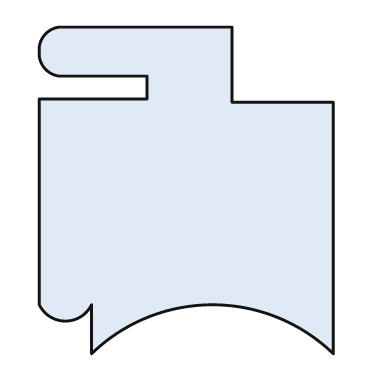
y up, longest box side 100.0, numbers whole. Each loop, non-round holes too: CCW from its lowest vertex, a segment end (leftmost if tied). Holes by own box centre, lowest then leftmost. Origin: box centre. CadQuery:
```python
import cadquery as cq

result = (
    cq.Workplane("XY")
    .moveTo(-29.0, -50.0)
    .threePointArc((8.0, -35.0), (45.0, -50.0))
    .lineTo(45.0, 27.0)
    .lineTo(14.0, 27.0)
    .lineTo(14.0, 50.0)
    .lineTo(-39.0, 50.0)
    .threePointArc((-43.0, 48.0), (-45.0, 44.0))
    .lineTo(-45.0, 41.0)
    .threePointArc((-43.0, 37.0), (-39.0, 35.0))
    .lineTo(-12.0, 35.0)
    .lineTo(-12.0, 28.0)
    .lineTo(-45.0, 28.0)
    .lineTo(-45.0, -35.0)
    .threePointArc((-37.0, -40.0), (-29.0, -35.0))
    .close()
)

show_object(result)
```